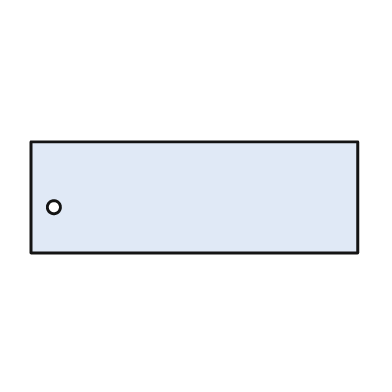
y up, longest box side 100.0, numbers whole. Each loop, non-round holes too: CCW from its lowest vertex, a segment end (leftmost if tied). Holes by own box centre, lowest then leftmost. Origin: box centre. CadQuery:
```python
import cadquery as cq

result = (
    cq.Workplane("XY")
    .moveTo(-50.0, -17.0)
    .lineTo(50.0, -17.0)
    .lineTo(50.0, 17.0)
    .lineTo(-50.0, 17.0)
    .close()
    .moveTo(-43.0, -3.0)
    .circle(2.0)
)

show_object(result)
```